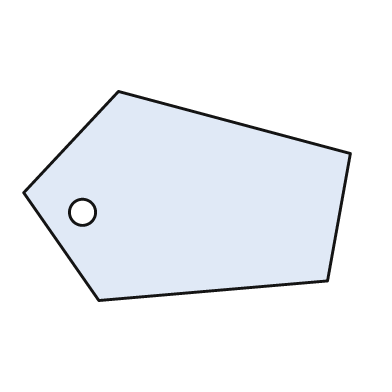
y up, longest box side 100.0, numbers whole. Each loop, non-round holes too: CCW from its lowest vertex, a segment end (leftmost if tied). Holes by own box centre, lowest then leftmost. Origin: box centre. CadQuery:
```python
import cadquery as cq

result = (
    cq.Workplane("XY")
    .moveTo(-27.0, -32.0)
    .lineTo(43.0, -26.0)
    .lineTo(50.0, 13.0)
    .lineTo(-21.0, 32.0)
    .lineTo(-50.0, 1.0)
    .close()
    .moveTo(-32.0, -5.0)
    .circle(4.0)
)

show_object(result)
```